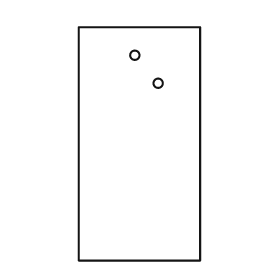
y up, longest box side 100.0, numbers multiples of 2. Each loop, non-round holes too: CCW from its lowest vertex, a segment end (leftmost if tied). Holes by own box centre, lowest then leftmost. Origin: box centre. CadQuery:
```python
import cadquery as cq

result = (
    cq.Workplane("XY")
    .moveTo(-26.0, -50.0)
    .lineTo(26.0, -50.0)
    .lineTo(26.0, 50.0)
    .lineTo(-26.0, 50.0)
    .close()
    .moveTo(8.0, 26.0)
    .circle(2.0)
    .moveTo(-2.0, 38.0)
    .circle(2.0)
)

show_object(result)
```